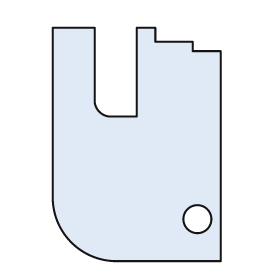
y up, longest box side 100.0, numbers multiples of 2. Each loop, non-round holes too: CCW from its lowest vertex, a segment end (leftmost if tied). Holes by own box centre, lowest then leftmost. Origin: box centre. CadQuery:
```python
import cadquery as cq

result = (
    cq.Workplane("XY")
    .moveTo(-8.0, -50.0)
    .lineTo(36.0, -50.0)
    .lineTo(36.0, 40.0)
    .lineTo(24.0, 40.0)
    .lineTo(24.0, 44.0)
    .lineTo(8.0, 44.0)
    .lineTo(8.0, 50.0)
    .lineTo(0.0, 50.0)
    .lineTo(0.0, 12.0)
    .lineTo(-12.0, 12.0)
    .threePointArc((-16.0, 14.0), (-18.0, 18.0))
    .lineTo(-18.0, 50.0)
    .lineTo(-36.0, 50.0)
    .lineTo(-36.0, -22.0)
    .threePointArc((-28.0, -42.0), (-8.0, -50.0))
    .close()
    .moveTo(26.0, -32.0)
    .circle(6.0)
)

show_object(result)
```